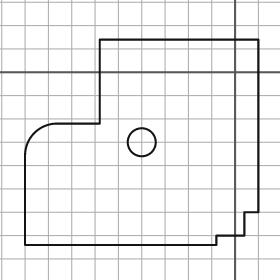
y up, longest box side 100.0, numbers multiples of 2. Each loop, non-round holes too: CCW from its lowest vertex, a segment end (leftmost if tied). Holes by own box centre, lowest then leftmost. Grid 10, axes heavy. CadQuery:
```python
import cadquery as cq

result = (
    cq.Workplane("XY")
    .moveTo(-90.0, -74.0)
    .lineTo(-8.0, -74.0)
    .lineTo(-8.0, -70.0)
    .lineTo(4.0, -70.0)
    .lineTo(4.0, -60.0)
    .lineTo(10.0, -60.0)
    .lineTo(10.0, 14.0)
    .lineTo(-58.0, 14.0)
    .lineTo(-58.0, -22.0)
    .lineTo(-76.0, -22.0)
    .threePointArc((-86.0, -26.0), (-90.0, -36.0))
    .close()
    .moveTo(-40.0, -30.0)
    .circle(6.0)
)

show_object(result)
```